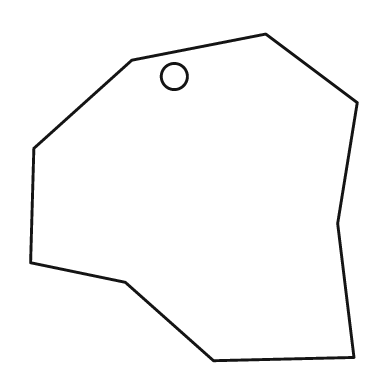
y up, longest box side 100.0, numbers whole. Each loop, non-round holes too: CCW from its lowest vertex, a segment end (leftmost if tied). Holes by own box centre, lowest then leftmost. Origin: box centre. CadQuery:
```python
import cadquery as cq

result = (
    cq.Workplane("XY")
    .moveTo(6.0, -50.0)
    .lineTo(49.0, -49.0)
    .lineTo(44.0, -8.0)
    .lineTo(50.0, 29.0)
    .lineTo(22.0, 50.0)
    .lineTo(-19.0, 42.0)
    .lineTo(-49.0, 15.0)
    .lineTo(-50.0, -20.0)
    .lineTo(-21.0, -26.0)
    .close()
    .moveTo(-6.0, 37.0)
    .circle(4.0)
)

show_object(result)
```